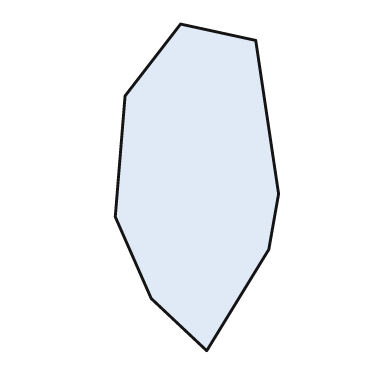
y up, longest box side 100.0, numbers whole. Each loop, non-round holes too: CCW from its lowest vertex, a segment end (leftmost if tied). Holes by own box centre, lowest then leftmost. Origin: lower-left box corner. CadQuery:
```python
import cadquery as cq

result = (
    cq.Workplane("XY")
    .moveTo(28.0, 0.0)
    .lineTo(47.0, 31.0)
    .lineTo(50.0, 48.0)
    .lineTo(43.0, 95.0)
    .lineTo(20.0, 100.0)
    .lineTo(3.0, 78.0)
    .lineTo(0.0, 41.0)
    .lineTo(11.0, 16.0)
    .close()
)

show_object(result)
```